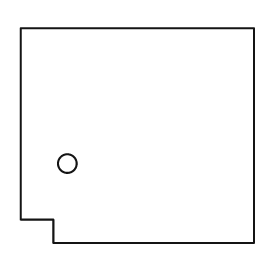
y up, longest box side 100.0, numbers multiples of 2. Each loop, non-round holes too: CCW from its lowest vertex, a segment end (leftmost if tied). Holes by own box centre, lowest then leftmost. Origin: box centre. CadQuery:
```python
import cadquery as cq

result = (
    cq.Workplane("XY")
    .moveTo(-36.0, -46.0)
    .lineTo(50.0, -46.0)
    .lineTo(50.0, 46.0)
    .lineTo(-50.0, 46.0)
    .lineTo(-50.0, -36.0)
    .lineTo(-36.0, -36.0)
    .close()
    .moveTo(-30.0, -12.0)
    .circle(4.0)
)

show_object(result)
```